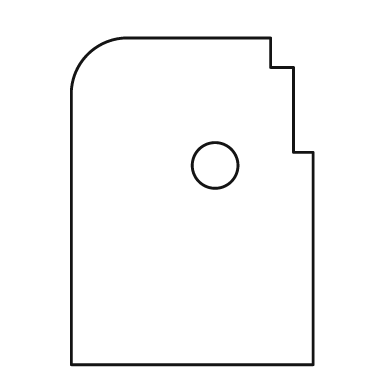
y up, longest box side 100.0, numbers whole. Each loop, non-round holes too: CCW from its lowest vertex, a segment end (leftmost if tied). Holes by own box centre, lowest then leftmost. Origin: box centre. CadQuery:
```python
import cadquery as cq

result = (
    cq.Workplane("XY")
    .moveTo(-37.0, -50.0)
    .lineTo(37.0, -50.0)
    .lineTo(37.0, 15.0)
    .lineTo(31.0, 15.0)
    .lineTo(31.0, 41.0)
    .lineTo(24.0, 41.0)
    .lineTo(24.0, 50.0)
    .lineTo(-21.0, 50.0)
    .threePointArc((-32.0, 45.0), (-37.0, 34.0))
    .close()
    .moveTo(7.0, 11.0)
    .circle(7.0)
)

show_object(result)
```